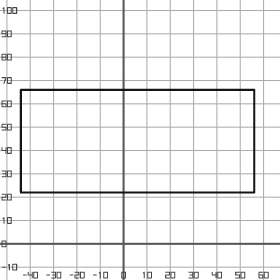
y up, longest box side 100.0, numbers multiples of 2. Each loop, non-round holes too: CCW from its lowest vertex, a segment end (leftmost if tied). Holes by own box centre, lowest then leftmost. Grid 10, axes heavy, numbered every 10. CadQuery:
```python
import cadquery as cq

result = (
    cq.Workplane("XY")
    .moveTo(-44.0, 22.0)
    .lineTo(56.0, 22.0)
    .lineTo(56.0, 66.0)
    .lineTo(-44.0, 66.0)
    .close()
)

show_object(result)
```